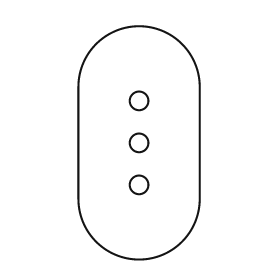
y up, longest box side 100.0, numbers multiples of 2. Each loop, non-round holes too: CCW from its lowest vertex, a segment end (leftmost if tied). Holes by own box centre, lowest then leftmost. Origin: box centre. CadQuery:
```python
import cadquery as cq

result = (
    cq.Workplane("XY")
    .moveTo(-26.0, -24.0)
    .threePointArc((0.0, -50.0), (26.0, -24.0))
    .lineTo(26.0, 24.0)
    .threePointArc((0.0, 50.0), (-26.0, 24.0))
    .close()
    .moveTo(0.0, -18.0)
    .circle(4.0)
    .moveTo(0.0, 0.0)
    .circle(4.0)
    .moveTo(0.0, 18.0)
    .circle(4.0)
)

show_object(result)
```